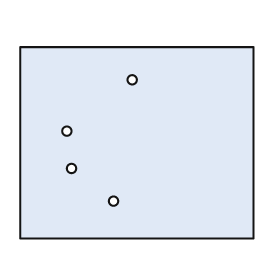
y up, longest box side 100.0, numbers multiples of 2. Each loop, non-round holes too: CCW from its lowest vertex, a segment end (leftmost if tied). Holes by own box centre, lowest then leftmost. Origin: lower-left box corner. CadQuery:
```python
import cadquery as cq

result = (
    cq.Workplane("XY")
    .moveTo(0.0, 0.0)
    .lineTo(100.0, 0.0)
    .lineTo(100.0, 82.0)
    .lineTo(0.0, 82.0)
    .close()
    .moveTo(40.0, 16.0)
    .circle(2.0)
    .moveTo(22.0, 30.0)
    .circle(2.0)
    .moveTo(20.0, 46.0)
    .circle(2.0)
    .moveTo(48.0, 68.0)
    .circle(2.0)
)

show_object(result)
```